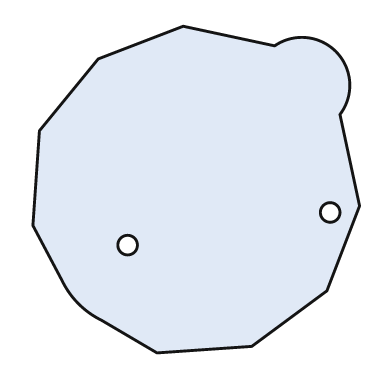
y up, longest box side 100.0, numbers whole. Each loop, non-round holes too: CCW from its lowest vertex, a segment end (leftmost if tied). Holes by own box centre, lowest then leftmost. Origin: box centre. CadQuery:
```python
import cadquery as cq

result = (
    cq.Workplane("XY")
    .moveTo(-12.0, -50.0)
    .lineTo(17.0, -48.0)
    .lineTo(40.0, -31.0)
    .lineTo(50.0, -5.0)
    .lineTo(44.0, 23.0)
    .threePointArc((43.0, 42.0), (24.0, 44.0))
    .lineTo(-4.0, 50.0)
    .lineTo(-30.0, 40.0)
    .lineTo(-48.0, 18.0)
    .lineTo(-50.0, -11.0)
    .lineTo(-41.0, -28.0)
    .threePointArc((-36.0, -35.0), (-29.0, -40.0))
    .close()
    .moveTo(-21.0, -17.0)
    .circle(3.0)
    .moveTo(41.0, -7.0)
    .circle(3.0)
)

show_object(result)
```